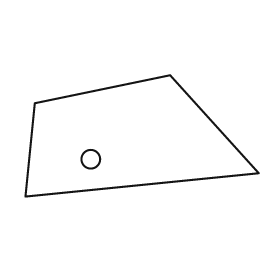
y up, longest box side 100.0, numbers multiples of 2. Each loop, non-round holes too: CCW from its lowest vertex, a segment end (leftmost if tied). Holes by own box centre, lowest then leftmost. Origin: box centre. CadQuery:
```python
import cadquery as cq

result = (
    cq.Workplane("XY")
    .moveTo(-50.0, -26.0)
    .lineTo(50.0, -16.0)
    .lineTo(12.0, 26.0)
    .lineTo(-46.0, 14.0)
    .close()
    .moveTo(-22.0, -10.0)
    .circle(4.0)
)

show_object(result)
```